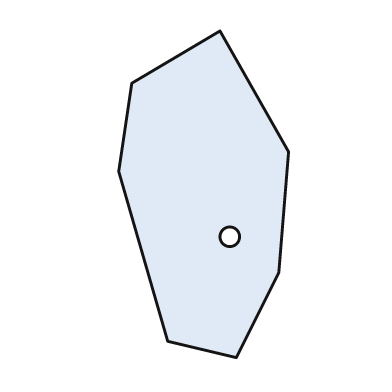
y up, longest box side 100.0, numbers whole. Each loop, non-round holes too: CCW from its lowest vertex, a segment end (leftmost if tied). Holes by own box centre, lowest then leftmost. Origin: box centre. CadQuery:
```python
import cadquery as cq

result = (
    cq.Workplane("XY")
    .moveTo(10.0, -50.0)
    .lineTo(23.0, -24.0)
    .lineTo(26.0, 13.0)
    .lineTo(5.0, 50.0)
    .lineTo(-22.0, 34.0)
    .lineTo(-26.0, 7.0)
    .lineTo(-11.0, -45.0)
    .close()
    .moveTo(8.0, -13.0)
    .circle(3.0)
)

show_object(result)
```